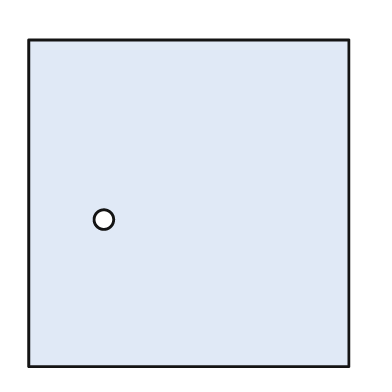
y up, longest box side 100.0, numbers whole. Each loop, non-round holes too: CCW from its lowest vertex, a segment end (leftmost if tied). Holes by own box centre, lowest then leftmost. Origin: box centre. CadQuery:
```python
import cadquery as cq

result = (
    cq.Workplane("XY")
    .moveTo(-49.0, -50.0)
    .lineTo(49.0, -50.0)
    .lineTo(49.0, 50.0)
    .lineTo(-49.0, 50.0)
    .close()
    .moveTo(-26.0, -5.0)
    .circle(3.0)
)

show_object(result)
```